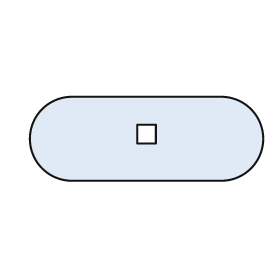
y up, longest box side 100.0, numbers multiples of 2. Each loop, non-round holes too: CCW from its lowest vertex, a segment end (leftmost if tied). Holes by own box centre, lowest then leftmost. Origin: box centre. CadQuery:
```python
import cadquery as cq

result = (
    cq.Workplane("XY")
    .moveTo(-32.0, -18.0)
    .lineTo(32.0, -18.0)
    .threePointArc((50.0, 0.0), (32.0, 18.0))
    .lineTo(-32.0, 18.0)
    .threePointArc((-50.0, 0.0), (-32.0, -18.0))
    .close()
    .moveTo(-4.0, -2.0)
    .lineTo(4.0, -2.0)
    .lineTo(4.0, 6.0)
    .lineTo(-4.0, 6.0)
    .close()
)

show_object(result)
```